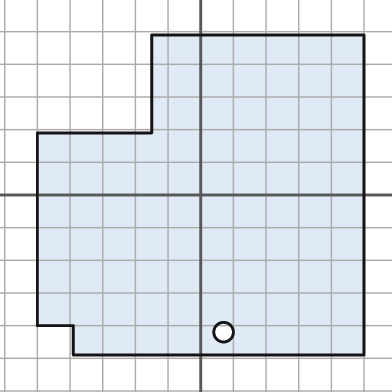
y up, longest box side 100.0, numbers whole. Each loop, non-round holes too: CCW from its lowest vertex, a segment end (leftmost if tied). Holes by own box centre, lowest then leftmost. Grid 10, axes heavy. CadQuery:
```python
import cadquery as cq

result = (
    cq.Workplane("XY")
    .moveTo(-39.0, -49.0)
    .lineTo(50.0, -49.0)
    .lineTo(50.0, 49.0)
    .lineTo(-15.0, 49.0)
    .lineTo(-15.0, 19.0)
    .lineTo(-50.0, 19.0)
    .lineTo(-50.0, -40.0)
    .lineTo(-39.0, -40.0)
    .close()
    .moveTo(7.0, -42.0)
    .circle(3.0)
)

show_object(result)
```